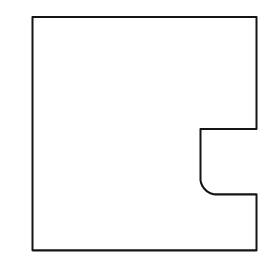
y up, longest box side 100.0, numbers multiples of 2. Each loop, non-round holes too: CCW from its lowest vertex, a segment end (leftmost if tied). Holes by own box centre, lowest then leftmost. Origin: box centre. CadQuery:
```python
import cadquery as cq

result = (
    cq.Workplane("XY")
    .moveTo(-48.0, -50.0)
    .lineTo(48.0, -50.0)
    .lineTo(48.0, -26.0)
    .lineTo(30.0, -26.0)
    .threePointArc((26.0, -24.0), (24.0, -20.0))
    .lineTo(24.0, 2.0)
    .lineTo(48.0, 2.0)
    .lineTo(48.0, 50.0)
    .lineTo(-48.0, 50.0)
    .close()
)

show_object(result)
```